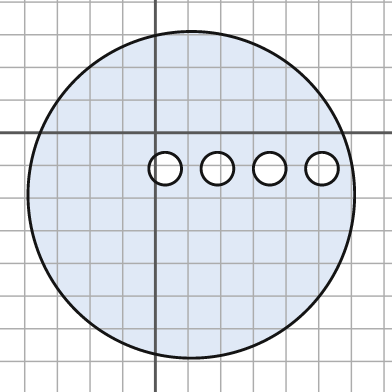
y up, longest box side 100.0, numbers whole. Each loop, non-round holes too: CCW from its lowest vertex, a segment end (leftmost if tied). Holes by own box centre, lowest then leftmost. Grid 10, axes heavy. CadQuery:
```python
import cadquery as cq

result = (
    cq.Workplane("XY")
    .moveTo(11.0, -19.0)
    .circle(50.0)
    .moveTo(3.0, -11.0)
    .circle(5.0)
    .moveTo(19.0, -11.0)
    .circle(5.0)
    .moveTo(35.0, -11.0)
    .circle(5.0)
    .moveTo(51.0, -11.0)
    .circle(5.0)
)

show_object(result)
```